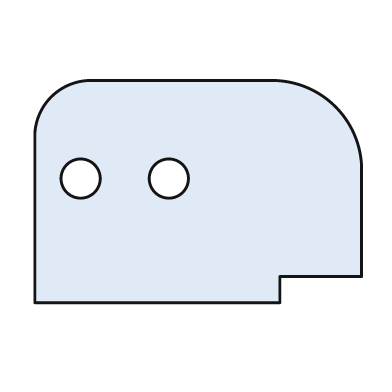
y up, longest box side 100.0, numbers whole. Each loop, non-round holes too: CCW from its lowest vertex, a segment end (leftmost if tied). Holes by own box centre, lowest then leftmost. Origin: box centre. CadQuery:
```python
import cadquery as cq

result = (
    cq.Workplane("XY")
    .moveTo(-50.0, -34.0)
    .lineTo(25.0, -34.0)
    .lineTo(25.0, -26.0)
    .lineTo(50.0, -26.0)
    .lineTo(50.0, 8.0)
    .threePointArc((42.0, 26.0), (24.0, 34.0))
    .lineTo(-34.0, 34.0)
    .threePointArc((-45.0, 29.0), (-50.0, 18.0))
    .close()
    .moveTo(-36.0, 4.0)
    .circle(6.0)
    .moveTo(-9.0, 4.0)
    .circle(6.0)
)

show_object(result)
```